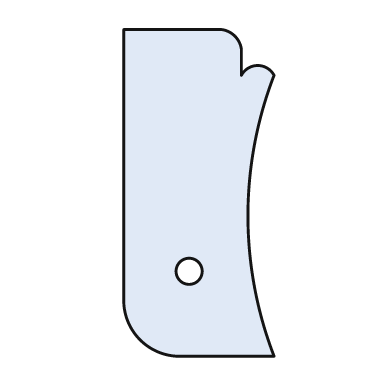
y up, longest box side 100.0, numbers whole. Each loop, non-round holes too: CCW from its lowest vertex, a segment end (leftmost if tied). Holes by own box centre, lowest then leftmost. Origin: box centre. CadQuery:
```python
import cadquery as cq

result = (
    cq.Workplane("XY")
    .moveTo(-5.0, -50.0)
    .lineTo(23.0, -50.0)
    .threePointArc((15.0, -7.0), (23.0, 36.0))
    .threePointArc((18.0, 39.0), (13.0, 36.0))
    .lineTo(13.0, 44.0)
    .threePointArc((11.0, 48.0), (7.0, 50.0))
    .lineTo(-23.0, 50.0)
    .lineTo(-23.0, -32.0)
    .threePointArc((-18.0, -45.0), (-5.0, -50.0))
    .close()
    .moveTo(-3.0, -24.0)
    .circle(4.0)
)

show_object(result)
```